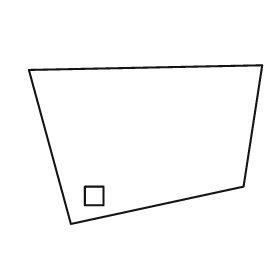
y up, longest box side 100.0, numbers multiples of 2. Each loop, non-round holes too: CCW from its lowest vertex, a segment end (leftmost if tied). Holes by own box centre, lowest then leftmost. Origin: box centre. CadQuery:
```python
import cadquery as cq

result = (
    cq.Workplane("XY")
    .moveTo(-32.0, -34.0)
    .lineTo(42.0, -18.0)
    .lineTo(50.0, 34.0)
    .lineTo(-50.0, 32.0)
    .close()
    .moveTo(-26.0, -26.0)
    .lineTo(-18.0, -26.0)
    .lineTo(-18.0, -18.0)
    .lineTo(-26.0, -18.0)
    .close()
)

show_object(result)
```